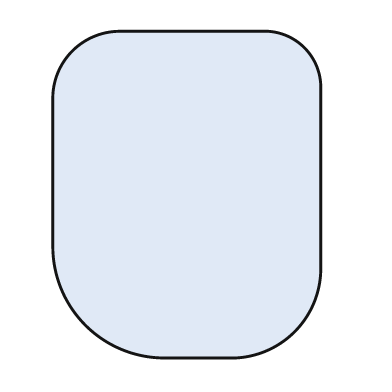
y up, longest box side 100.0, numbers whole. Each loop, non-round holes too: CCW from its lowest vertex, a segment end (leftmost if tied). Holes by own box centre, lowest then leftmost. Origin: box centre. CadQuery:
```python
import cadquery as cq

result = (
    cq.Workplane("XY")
    .moveTo(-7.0, -50.0)
    .lineTo(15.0, -50.0)
    .threePointArc((33.0, -42.0), (41.0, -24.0))
    .lineTo(41.0, 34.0)
    .threePointArc((36.0, 45.0), (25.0, 50.0))
    .lineTo(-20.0, 50.0)
    .threePointArc((-35.0, 44.0), (-41.0, 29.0))
    .lineTo(-41.0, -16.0)
    .threePointArc((-31.0, -40.0), (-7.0, -50.0))
    .close()
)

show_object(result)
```